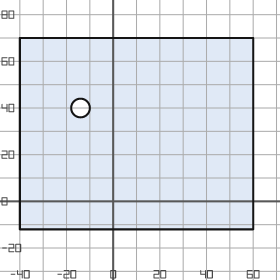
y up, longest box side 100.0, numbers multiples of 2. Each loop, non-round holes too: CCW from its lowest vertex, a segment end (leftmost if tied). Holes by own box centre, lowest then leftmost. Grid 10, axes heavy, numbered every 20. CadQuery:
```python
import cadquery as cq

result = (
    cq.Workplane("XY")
    .moveTo(-40.0, -12.0)
    .lineTo(60.0, -12.0)
    .lineTo(60.0, 70.0)
    .lineTo(-40.0, 70.0)
    .close()
    .moveTo(-14.0, 40.0)
    .circle(4.0)
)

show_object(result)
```